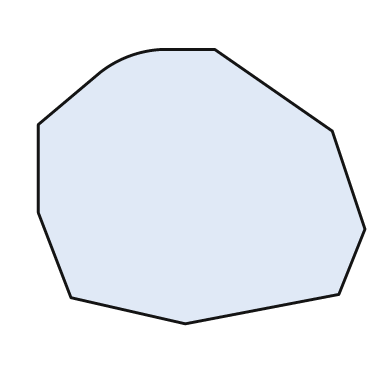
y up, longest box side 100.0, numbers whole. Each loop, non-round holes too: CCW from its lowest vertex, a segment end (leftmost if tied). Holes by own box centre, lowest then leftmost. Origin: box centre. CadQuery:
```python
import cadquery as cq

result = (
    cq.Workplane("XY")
    .moveTo(-5.0, -42.0)
    .lineTo(42.0, -33.0)
    .lineTo(50.0, -13.0)
    .lineTo(40.0, 17.0)
    .lineTo(4.0, 42.0)
    .lineTo(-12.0, 42.0)
    .threePointArc((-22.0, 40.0), (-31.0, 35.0))
    .lineTo(-50.0, 19.0)
    .lineTo(-50.0, -8.0)
    .lineTo(-40.0, -34.0)
    .close()
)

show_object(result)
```